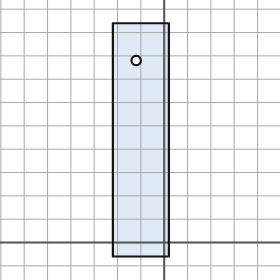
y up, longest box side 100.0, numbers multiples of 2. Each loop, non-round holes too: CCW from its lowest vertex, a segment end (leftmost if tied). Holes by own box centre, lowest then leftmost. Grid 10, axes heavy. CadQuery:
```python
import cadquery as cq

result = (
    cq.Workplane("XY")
    .moveTo(-22.0, -6.0)
    .lineTo(2.0, -6.0)
    .lineTo(2.0, 94.0)
    .lineTo(-22.0, 94.0)
    .close()
    .moveTo(-12.0, 78.0)
    .circle(2.0)
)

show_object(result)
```